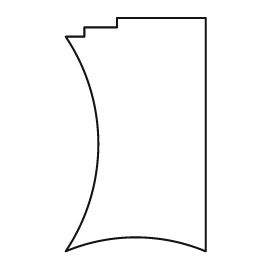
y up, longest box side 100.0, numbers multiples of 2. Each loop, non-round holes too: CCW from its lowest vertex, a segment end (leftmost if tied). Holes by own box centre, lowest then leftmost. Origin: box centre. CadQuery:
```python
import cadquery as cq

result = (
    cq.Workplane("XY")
    .moveTo(-30.0, -50.0)
    .threePointArc((0.0, -44.0), (30.0, -50.0))
    .lineTo(30.0, 50.0)
    .lineTo(-8.0, 50.0)
    .lineTo(-8.0, 46.0)
    .lineTo(-22.0, 46.0)
    .lineTo(-22.0, 42.0)
    .lineTo(-30.0, 42.0)
    .threePointArc((-16.0, -4.0), (-30.0, -50.0))
    .close()
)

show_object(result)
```